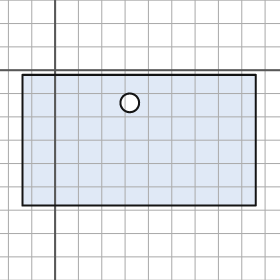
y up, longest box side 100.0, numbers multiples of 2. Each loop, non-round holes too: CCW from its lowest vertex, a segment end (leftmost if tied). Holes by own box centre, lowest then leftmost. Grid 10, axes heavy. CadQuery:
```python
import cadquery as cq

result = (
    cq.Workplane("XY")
    .moveTo(-14.0, -58.0)
    .lineTo(86.0, -58.0)
    .lineTo(86.0, -2.0)
    .lineTo(-14.0, -2.0)
    .close()
    .moveTo(32.0, -14.0)
    .circle(4.0)
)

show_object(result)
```